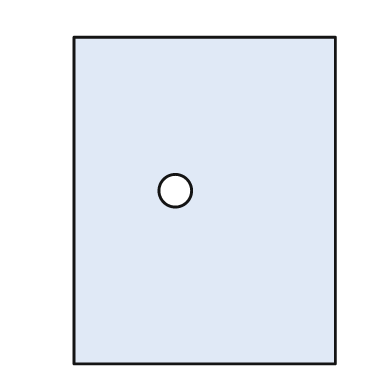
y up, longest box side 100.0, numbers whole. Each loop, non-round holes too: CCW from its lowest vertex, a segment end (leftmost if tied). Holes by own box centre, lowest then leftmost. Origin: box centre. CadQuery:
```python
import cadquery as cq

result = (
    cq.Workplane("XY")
    .moveTo(-40.0, -50.0)
    .lineTo(40.0, -50.0)
    .lineTo(40.0, 50.0)
    .lineTo(-40.0, 50.0)
    .close()
    .moveTo(-9.0, 3.0)
    .circle(5.0)
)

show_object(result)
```